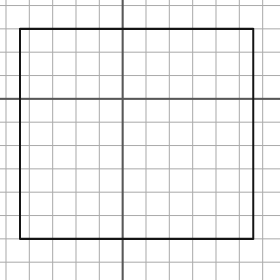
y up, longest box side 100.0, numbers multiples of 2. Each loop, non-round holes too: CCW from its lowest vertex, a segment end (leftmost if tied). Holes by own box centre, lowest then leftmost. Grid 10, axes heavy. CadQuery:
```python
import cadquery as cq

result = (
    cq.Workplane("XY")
    .moveTo(-44.0, -60.0)
    .lineTo(56.0, -60.0)
    .lineTo(56.0, 30.0)
    .lineTo(-44.0, 30.0)
    .close()
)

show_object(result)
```